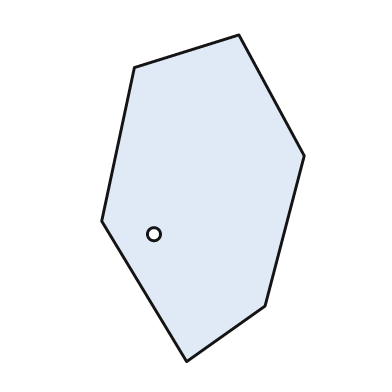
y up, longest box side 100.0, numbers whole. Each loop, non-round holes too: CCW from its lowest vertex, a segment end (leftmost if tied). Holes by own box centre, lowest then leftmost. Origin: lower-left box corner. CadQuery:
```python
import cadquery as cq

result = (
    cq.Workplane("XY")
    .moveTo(26.0, 0.0)
    .lineTo(50.0, 17.0)
    .lineTo(62.0, 63.0)
    .lineTo(42.0, 100.0)
    .lineTo(10.0, 90.0)
    .lineTo(0.0, 43.0)
    .close()
    .moveTo(16.0, 39.0)
    .circle(2.0)
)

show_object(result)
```